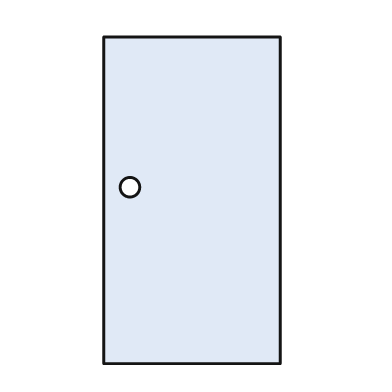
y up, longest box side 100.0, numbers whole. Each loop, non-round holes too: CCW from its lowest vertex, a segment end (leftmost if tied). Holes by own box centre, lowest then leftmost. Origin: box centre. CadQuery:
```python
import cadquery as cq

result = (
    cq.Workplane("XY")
    .moveTo(-27.0, -50.0)
    .lineTo(27.0, -50.0)
    .lineTo(27.0, 50.0)
    .lineTo(-27.0, 50.0)
    .close()
    .moveTo(-19.0, 4.0)
    .circle(3.0)
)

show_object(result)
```